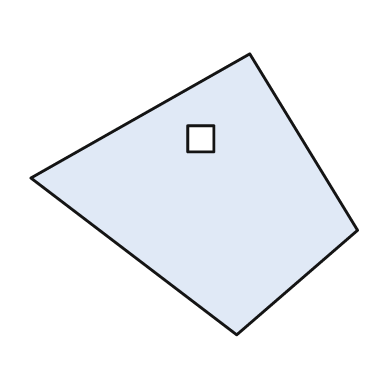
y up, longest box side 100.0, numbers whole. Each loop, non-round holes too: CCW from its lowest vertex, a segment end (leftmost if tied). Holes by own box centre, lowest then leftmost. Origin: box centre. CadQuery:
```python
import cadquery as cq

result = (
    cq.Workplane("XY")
    .moveTo(13.0, -43.0)
    .lineTo(50.0, -11.0)
    .lineTo(17.0, 43.0)
    .lineTo(-50.0, 5.0)
    .close()
    .moveTo(-2.0, 13.0)
    .lineTo(6.0, 13.0)
    .lineTo(6.0, 21.0)
    .lineTo(-2.0, 21.0)
    .close()
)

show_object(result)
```